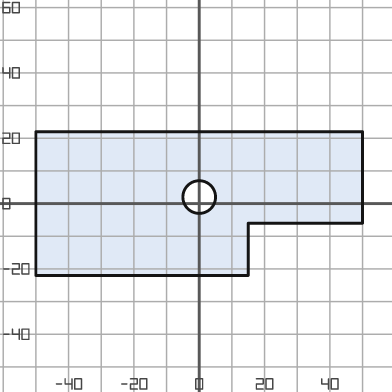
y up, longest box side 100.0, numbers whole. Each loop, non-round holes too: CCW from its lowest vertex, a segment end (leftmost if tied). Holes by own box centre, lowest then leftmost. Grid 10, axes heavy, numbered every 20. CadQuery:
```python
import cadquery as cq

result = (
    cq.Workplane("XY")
    .moveTo(-50.0, -22.0)
    .lineTo(15.0, -22.0)
    .lineTo(15.0, -6.0)
    .lineTo(50.0, -6.0)
    .lineTo(50.0, 22.0)
    .lineTo(-50.0, 22.0)
    .close()
    .moveTo(0.0, 2.0)
    .circle(5.0)
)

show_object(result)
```